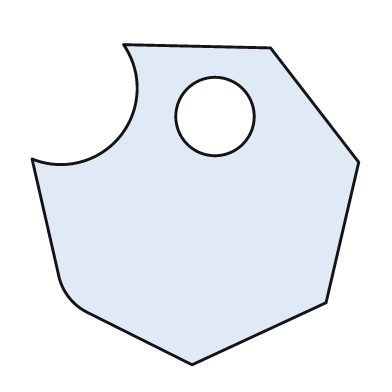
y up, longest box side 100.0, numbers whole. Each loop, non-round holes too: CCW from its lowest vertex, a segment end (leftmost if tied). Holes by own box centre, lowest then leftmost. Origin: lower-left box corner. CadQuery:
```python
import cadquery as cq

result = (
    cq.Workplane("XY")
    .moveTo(49.0, 0.0)
    .lineTo(90.0, 19.0)
    .lineTo(100.0, 62.0)
    .lineTo(73.0, 97.0)
    .lineTo(28.0, 98.0)
    .threePointArc((27.0, 70.0), (0.0, 63.0))
    .lineTo(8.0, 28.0)
    .threePointArc((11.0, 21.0), (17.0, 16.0))
    .close()
    .moveTo(56.0, 76.0)
    .circle(12.0)
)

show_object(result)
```